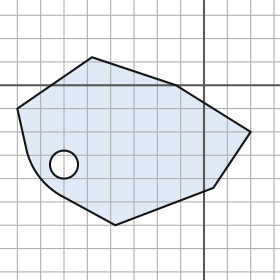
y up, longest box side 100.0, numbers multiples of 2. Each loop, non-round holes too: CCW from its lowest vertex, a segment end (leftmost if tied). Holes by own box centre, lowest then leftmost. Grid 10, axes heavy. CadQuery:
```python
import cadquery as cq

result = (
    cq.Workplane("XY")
    .moveTo(-38.0, -60.0)
    .lineTo(4.0, -44.0)
    .lineTo(20.0, -20.0)
    .lineTo(-12.0, 0.0)
    .lineTo(-48.0, 12.0)
    .lineTo(-80.0, -10.0)
    .lineTo(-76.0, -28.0)
    .threePointArc((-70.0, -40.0), (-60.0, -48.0))
    .close()
    .moveTo(-60.0, -34.0)
    .circle(6.0)
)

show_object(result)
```